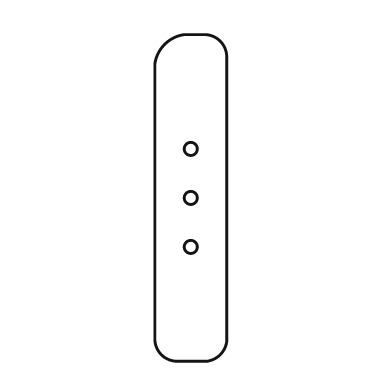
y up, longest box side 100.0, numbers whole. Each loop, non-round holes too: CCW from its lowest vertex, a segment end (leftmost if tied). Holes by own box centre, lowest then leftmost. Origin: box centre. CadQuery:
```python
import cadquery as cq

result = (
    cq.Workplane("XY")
    .moveTo(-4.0, -50.0)
    .lineTo(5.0, -50.0)
    .threePointArc((9.0, -48.0), (11.0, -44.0))
    .lineTo(11.0, 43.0)
    .threePointArc((9.0, 48.0), (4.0, 50.0))
    .lineTo(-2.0, 50.0)
    .threePointArc((-8.0, 47.0), (-11.0, 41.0))
    .lineTo(-11.0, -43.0)
    .threePointArc((-9.0, -48.0), (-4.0, -50.0))
    .close()
    .moveTo(0.0, -15.0)
    .circle(2.0)
    .moveTo(0.0, 0.0)
    .circle(2.0)
    .moveTo(0.0, 15.0)
    .circle(2.0)
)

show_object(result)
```